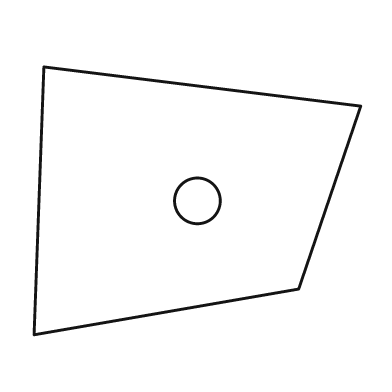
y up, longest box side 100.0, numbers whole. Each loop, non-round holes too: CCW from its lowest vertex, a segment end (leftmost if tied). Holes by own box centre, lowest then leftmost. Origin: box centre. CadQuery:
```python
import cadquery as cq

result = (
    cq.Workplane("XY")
    .moveTo(-50.0, -41.0)
    .lineTo(31.0, -27.0)
    .lineTo(50.0, 29.0)
    .lineTo(-47.0, 41.0)
    .close()
    .moveTo(0.0, 0.0)
    .circle(7.0)
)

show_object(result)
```